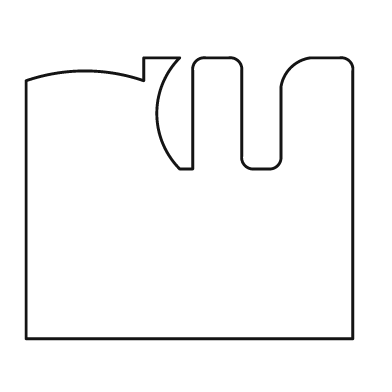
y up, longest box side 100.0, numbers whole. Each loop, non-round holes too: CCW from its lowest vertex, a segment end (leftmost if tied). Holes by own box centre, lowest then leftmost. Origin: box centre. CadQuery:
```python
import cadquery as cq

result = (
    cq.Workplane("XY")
    .moveTo(-50.0, -43.0)
    .lineTo(50.0, -43.0)
    .lineTo(50.0, 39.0)
    .threePointArc((49.0, 42.0), (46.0, 43.0))
    .lineTo(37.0, 43.0)
    .threePointArc((31.0, 40.0), (28.0, 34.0))
    .lineTo(28.0, 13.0)
    .threePointArc((27.0, 10.0), (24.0, 9.0))
    .lineTo(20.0, 9.0)
    .threePointArc((17.0, 10.0), (16.0, 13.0))
    .lineTo(16.0, 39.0)
    .threePointArc((15.0, 42.0), (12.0, 43.0))
    .lineTo(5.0, 43.0)
    .threePointArc((2.0, 42.0), (1.0, 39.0))
    .lineTo(1.0, 9.0)
    .lineTo(-3.0, 9.0)
    .threePointArc((-10.0, 26.0), (-3.0, 43.0))
    .lineTo(-14.0, 43.0)
    .lineTo(-14.0, 36.0)
    .threePointArc((-32.0, 39.0), (-50.0, 36.0))
    .close()
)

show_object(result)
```